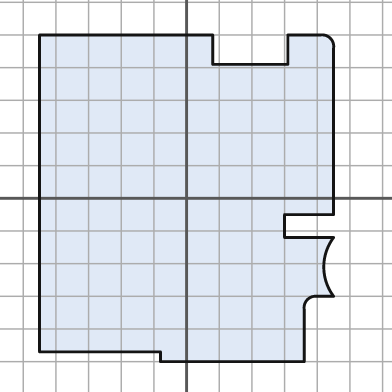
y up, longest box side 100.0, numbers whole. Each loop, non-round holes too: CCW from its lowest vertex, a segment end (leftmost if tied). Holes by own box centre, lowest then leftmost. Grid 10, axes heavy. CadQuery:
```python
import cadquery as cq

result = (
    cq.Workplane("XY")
    .moveTo(-8.0, -50.0)
    .lineTo(36.0, -50.0)
    .lineTo(36.0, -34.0)
    .threePointArc((37.0, -31.0), (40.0, -30.0))
    .lineTo(45.0, -30.0)
    .threePointArc((42.0, -21.0), (45.0, -12.0))
    .lineTo(30.0, -12.0)
    .lineTo(30.0, -5.0)
    .lineTo(45.0, -5.0)
    .lineTo(45.0, 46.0)
    .threePointArc((44.0, 49.0), (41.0, 50.0))
    .lineTo(31.0, 50.0)
    .lineTo(31.0, 41.0)
    .lineTo(8.0, 41.0)
    .lineTo(8.0, 50.0)
    .lineTo(-45.0, 50.0)
    .lineTo(-45.0, -47.0)
    .lineTo(-8.0, -47.0)
    .close()
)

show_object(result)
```